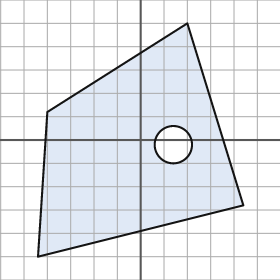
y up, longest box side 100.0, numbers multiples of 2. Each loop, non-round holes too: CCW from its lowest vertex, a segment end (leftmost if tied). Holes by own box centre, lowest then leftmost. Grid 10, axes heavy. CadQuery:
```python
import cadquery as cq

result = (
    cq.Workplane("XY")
    .moveTo(-44.0, -50.0)
    .lineTo(44.0, -28.0)
    .lineTo(20.0, 50.0)
    .lineTo(-40.0, 12.0)
    .close()
    .moveTo(14.0, -2.0)
    .circle(8.0)
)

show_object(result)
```